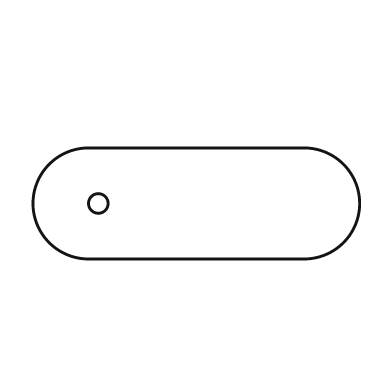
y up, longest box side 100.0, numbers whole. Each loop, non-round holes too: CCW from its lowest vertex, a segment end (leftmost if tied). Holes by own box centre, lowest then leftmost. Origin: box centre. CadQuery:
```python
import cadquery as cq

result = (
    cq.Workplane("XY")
    .moveTo(-33.0, -17.0)
    .lineTo(33.0, -17.0)
    .threePointArc((50.0, 0.0), (33.0, 17.0))
    .lineTo(-33.0, 17.0)
    .threePointArc((-50.0, 0.0), (-33.0, -17.0))
    .close()
    .moveTo(-30.0, 0.0)
    .circle(3.0)
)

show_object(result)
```